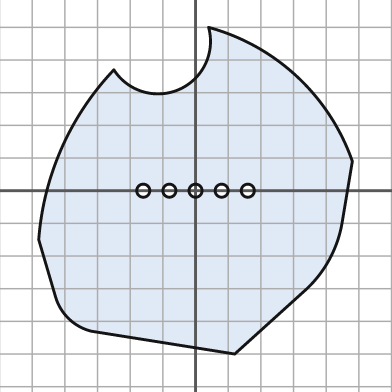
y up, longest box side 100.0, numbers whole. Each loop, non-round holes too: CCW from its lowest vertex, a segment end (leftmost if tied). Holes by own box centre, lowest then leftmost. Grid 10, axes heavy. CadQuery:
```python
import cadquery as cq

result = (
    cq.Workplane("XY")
    .moveTo(12.0, -50.0)
    .lineTo(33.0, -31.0)
    .threePointArc((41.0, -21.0), (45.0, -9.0))
    .lineTo(48.0, 9.0)
    .threePointArc((31.0, 35.0), (4.0, 50.0))
    .threePointArc((-5.0, 31.0), (-25.0, 37.0))
    .threePointArc((-41.0, 13.0), (-48.0, -15.0))
    .lineTo(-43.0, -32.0)
    .threePointArc((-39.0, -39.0), (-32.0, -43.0))
    .close()
    .moveTo(-16.0, 0.0)
    .circle(2.0)
    .moveTo(-8.0, 0.0)
    .circle(2.0)
    .moveTo(0.0, 0.0)
    .circle(2.0)
    .moveTo(8.0, 0.0)
    .circle(2.0)
    .moveTo(16.0, 0.0)
    .circle(2.0)
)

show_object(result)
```